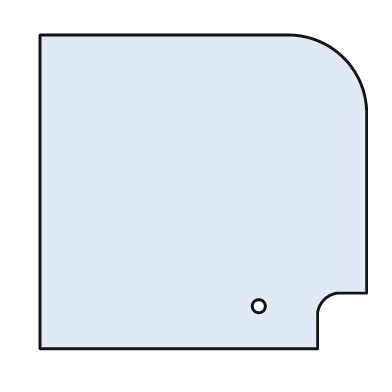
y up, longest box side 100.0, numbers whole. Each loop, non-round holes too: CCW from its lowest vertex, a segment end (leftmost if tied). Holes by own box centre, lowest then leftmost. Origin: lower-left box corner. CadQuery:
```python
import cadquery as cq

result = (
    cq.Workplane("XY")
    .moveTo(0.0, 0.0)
    .lineTo(85.0, 0.0)
    .lineTo(85.0, 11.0)
    .threePointArc((87.0, 15.0), (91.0, 17.0))
    .lineTo(100.0, 17.0)
    .lineTo(100.0, 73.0)
    .threePointArc((93.0, 89.0), (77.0, 96.0))
    .lineTo(0.0, 96.0)
    .close()
    .moveTo(67.0, 13.0)
    .circle(2.0)
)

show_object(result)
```